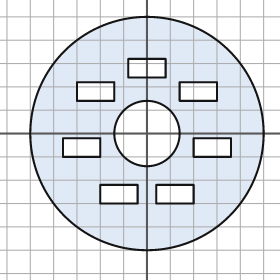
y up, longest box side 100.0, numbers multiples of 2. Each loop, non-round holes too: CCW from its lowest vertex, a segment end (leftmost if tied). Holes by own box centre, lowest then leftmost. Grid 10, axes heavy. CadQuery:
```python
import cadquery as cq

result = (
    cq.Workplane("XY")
    .moveTo(0.0, 0.0)
    .circle(50.0)
    .moveTo(-20.0, -30.0)
    .lineTo(-4.0, -30.0)
    .lineTo(-4.0, -22.0)
    .lineTo(-20.0, -22.0)
    .close()
    .moveTo(4.0, -30.0)
    .lineTo(20.0, -30.0)
    .lineTo(20.0, -22.0)
    .lineTo(4.0, -22.0)
    .close()
    .moveTo(-36.0, -10.0)
    .lineTo(-20.0, -10.0)
    .lineTo(-20.0, -2.0)
    .lineTo(-36.0, -2.0)
    .close()
    .moveTo(20.0, -10.0)
    .lineTo(36.0, -10.0)
    .lineTo(36.0, -2.0)
    .lineTo(20.0, -2.0)
    .close()
    .moveTo(0.0, 0.0)
    .circle(14.0)
    .moveTo(-30.0, 14.0)
    .lineTo(-14.0, 14.0)
    .lineTo(-14.0, 22.0)
    .lineTo(-30.0, 22.0)
    .close()
    .moveTo(14.0, 14.0)
    .lineTo(30.0, 14.0)
    .lineTo(30.0, 22.0)
    .lineTo(14.0, 22.0)
    .close()
    .moveTo(-8.0, 24.0)
    .lineTo(8.0, 24.0)
    .lineTo(8.0, 32.0)
    .lineTo(-8.0, 32.0)
    .close()
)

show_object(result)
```